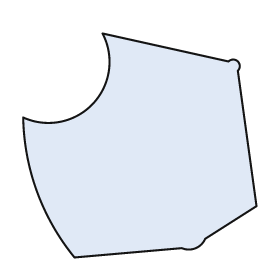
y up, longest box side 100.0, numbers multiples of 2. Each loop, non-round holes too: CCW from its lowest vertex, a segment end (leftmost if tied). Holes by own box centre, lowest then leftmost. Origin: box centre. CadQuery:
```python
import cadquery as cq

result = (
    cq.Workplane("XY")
    .moveTo(-28.0, -48.0)
    .lineTo(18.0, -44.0)
    .threePointArc((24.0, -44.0), (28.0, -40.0))
    .lineTo(50.0, -26.0)
    .lineTo(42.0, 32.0)
    .threePointArc((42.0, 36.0), (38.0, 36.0))
    .lineTo(-16.0, 48.0)
    .threePointArc((-20.0, 18.0), (-50.0, 12.0))
    .threePointArc((-44.0, -20.0), (-28.0, -48.0))
    .close()
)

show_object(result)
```